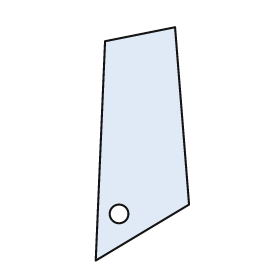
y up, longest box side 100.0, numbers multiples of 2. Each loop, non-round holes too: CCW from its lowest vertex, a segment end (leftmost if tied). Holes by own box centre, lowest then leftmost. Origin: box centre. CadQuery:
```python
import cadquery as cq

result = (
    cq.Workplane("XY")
    .moveTo(-20.0, -50.0)
    .lineTo(20.0, -26.0)
    .lineTo(14.0, 50.0)
    .lineTo(-16.0, 44.0)
    .close()
    .moveTo(-10.0, -30.0)
    .circle(4.0)
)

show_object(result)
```